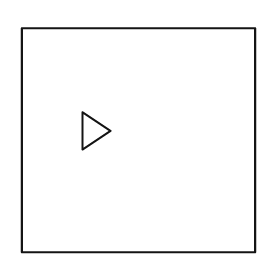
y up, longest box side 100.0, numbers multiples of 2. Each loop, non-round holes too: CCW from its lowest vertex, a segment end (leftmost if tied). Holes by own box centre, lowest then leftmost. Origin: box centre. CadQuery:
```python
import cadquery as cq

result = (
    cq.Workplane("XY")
    .moveTo(-50.0, -48.0)
    .lineTo(50.0, -48.0)
    .lineTo(50.0, 48.0)
    .lineTo(-50.0, 48.0)
    .close()
    .moveTo(-24.0, -4.0)
    .lineTo(-12.0, 4.0)
    .lineTo(-24.0, 12.0)
    .close()
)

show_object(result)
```